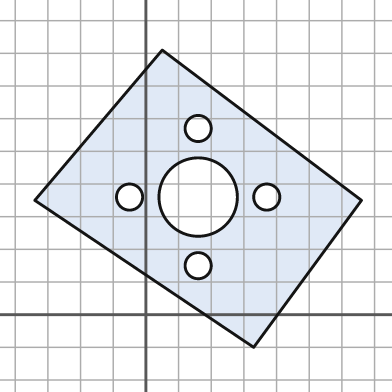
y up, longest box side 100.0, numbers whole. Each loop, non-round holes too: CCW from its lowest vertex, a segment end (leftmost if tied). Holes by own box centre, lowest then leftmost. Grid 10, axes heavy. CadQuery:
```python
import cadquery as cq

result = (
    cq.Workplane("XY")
    .moveTo(33.0, -10.0)
    .lineTo(66.0, 35.0)
    .lineTo(5.0, 81.0)
    .lineTo(-34.0, 35.0)
    .close()
    .moveTo(16.0, 15.0)
    .circle(4.0)
    .moveTo(-5.0, 36.0)
    .circle(4.0)
    .moveTo(16.0, 36.0)
    .circle(12.0)
    .moveTo(37.0, 36.0)
    .circle(4.0)
    .moveTo(16.0, 57.0)
    .circle(4.0)
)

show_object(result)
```